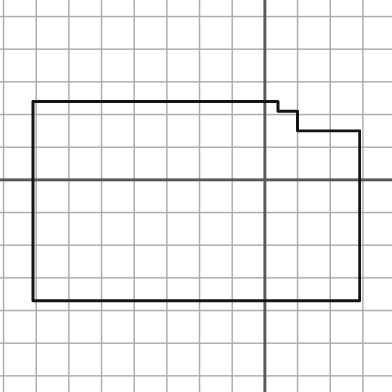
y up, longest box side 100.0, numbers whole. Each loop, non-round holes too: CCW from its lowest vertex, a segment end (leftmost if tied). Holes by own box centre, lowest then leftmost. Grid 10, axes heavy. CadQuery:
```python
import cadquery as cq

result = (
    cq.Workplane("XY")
    .moveTo(-71.0, -37.0)
    .lineTo(29.0, -37.0)
    .lineTo(29.0, 15.0)
    .lineTo(10.0, 15.0)
    .lineTo(10.0, 21.0)
    .lineTo(4.0, 21.0)
    .lineTo(4.0, 24.0)
    .lineTo(-71.0, 24.0)
    .close()
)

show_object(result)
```